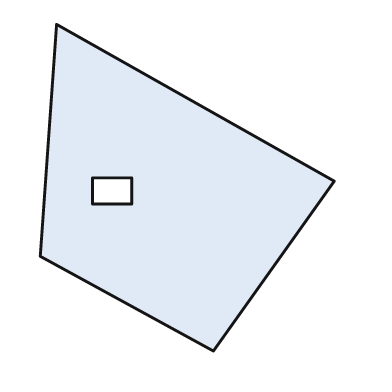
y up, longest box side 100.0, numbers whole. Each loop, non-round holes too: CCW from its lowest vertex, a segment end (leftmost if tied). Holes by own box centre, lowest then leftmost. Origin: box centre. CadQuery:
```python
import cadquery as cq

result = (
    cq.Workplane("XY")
    .moveTo(8.0, -50.0)
    .lineTo(45.0, 2.0)
    .lineTo(-40.0, 50.0)
    .lineTo(-45.0, -21.0)
    .close()
    .moveTo(-29.0, -5.0)
    .lineTo(-17.0, -5.0)
    .lineTo(-17.0, 3.0)
    .lineTo(-29.0, 3.0)
    .close()
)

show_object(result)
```